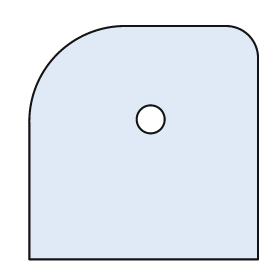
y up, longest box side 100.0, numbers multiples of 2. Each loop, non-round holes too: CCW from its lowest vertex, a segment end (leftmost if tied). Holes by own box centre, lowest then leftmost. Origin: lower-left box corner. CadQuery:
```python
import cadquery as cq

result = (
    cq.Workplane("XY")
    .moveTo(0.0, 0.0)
    .lineTo(98.0, 0.0)
    .lineTo(98.0, 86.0)
    .threePointArc((94.0, 96.0), (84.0, 100.0))
    .lineTo(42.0, 100.0)
    .threePointArc((12.0, 88.0), (0.0, 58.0))
    .close()
    .moveTo(52.0, 60.0)
    .circle(6.0)
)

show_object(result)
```